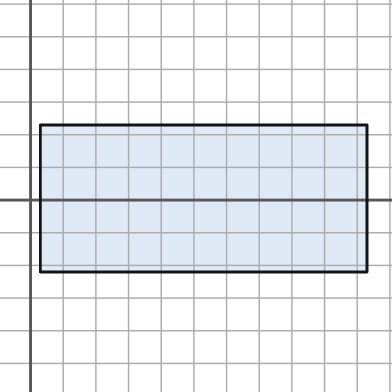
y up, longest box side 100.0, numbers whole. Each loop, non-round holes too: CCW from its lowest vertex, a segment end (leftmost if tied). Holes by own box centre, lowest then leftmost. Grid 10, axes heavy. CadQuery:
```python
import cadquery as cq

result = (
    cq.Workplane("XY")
    .moveTo(3.0, -22.0)
    .lineTo(103.0, -22.0)
    .lineTo(103.0, 23.0)
    .lineTo(3.0, 23.0)
    .close()
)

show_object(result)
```